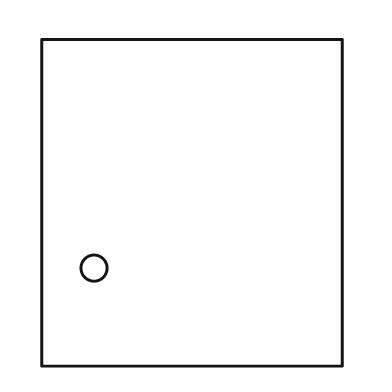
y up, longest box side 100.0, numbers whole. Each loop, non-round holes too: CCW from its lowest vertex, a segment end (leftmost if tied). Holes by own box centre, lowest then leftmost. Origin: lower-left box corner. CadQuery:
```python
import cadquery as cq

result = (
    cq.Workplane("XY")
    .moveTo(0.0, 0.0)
    .lineTo(92.0, 0.0)
    .lineTo(92.0, 100.0)
    .lineTo(0.0, 100.0)
    .close()
    .moveTo(16.0, 30.0)
    .circle(4.0)
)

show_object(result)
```